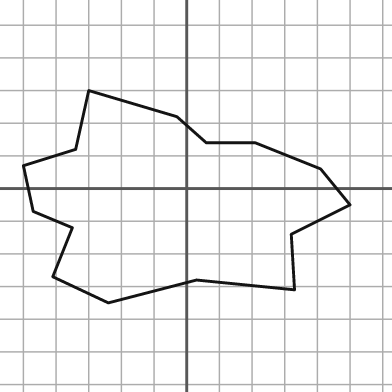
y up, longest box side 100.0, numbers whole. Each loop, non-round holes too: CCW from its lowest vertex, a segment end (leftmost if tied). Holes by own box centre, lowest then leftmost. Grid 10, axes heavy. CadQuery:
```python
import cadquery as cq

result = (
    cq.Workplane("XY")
    .moveTo(-24.0, -35.0)
    .lineTo(3.0, -28.0)
    .lineTo(33.0, -31.0)
    .lineTo(32.0, -14.0)
    .lineTo(50.0, -5.0)
    .lineTo(41.0, 6.0)
    .lineTo(21.0, 14.0)
    .lineTo(6.0, 14.0)
    .lineTo(-3.0, 22.0)
    .lineTo(-30.0, 30.0)
    .lineTo(-34.0, 12.0)
    .lineTo(-50.0, 7.0)
    .lineTo(-47.0, -7.0)
    .lineTo(-35.0, -12.0)
    .lineTo(-41.0, -27.0)
    .close()
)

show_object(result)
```